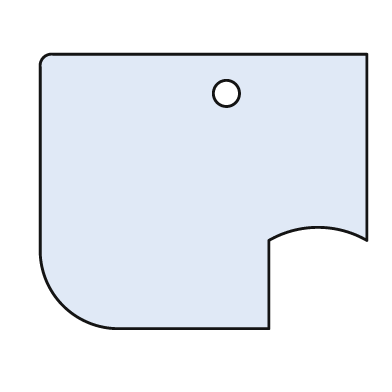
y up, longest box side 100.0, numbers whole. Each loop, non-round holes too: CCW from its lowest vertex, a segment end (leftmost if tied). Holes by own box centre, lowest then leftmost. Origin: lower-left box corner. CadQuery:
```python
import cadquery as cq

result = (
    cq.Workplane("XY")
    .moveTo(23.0, 0.0)
    .lineTo(70.0, 0.0)
    .lineTo(70.0, 27.0)
    .threePointArc((85.0, 31.0), (100.0, 27.0))
    .lineTo(100.0, 84.0)
    .lineTo(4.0, 84.0)
    .threePointArc((1.0, 83.0), (0.0, 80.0))
    .lineTo(0.0, 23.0)
    .threePointArc((7.0, 7.0), (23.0, 0.0))
    .close()
    .moveTo(57.0, 72.0)
    .circle(4.0)
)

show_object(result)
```